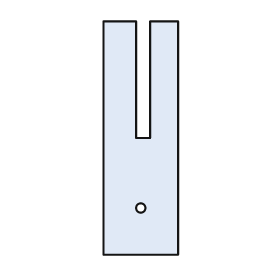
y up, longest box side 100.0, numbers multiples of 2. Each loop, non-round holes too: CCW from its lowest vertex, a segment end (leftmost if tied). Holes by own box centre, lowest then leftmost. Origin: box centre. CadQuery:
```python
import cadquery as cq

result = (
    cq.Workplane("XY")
    .moveTo(-16.0, -50.0)
    .lineTo(16.0, -50.0)
    .lineTo(16.0, 50.0)
    .lineTo(4.0, 50.0)
    .lineTo(4.0, 0.0)
    .lineTo(-2.0, 0.0)
    .lineTo(-2.0, 50.0)
    .lineTo(-16.0, 50.0)
    .close()
    .moveTo(0.0, -30.0)
    .circle(2.0)
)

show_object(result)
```